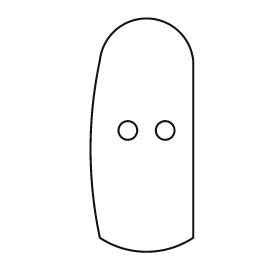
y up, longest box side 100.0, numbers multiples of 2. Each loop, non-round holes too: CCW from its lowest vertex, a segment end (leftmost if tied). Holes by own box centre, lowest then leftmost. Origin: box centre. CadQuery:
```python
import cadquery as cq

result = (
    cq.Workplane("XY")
    .moveTo(-18.0, -44.0)
    .threePointArc((2.0, -50.0), (22.0, -44.0))
    .lineTo(22.0, 32.0)
    .threePointArc((2.0, 50.0), (-18.0, 32.0))
    .threePointArc((-22.0, -6.0), (-18.0, -44.0))
    .close()
    .moveTo(-6.0, 2.0)
    .circle(4.0)
    .moveTo(10.0, 2.0)
    .circle(4.0)
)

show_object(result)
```